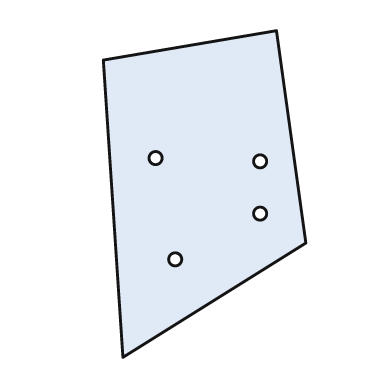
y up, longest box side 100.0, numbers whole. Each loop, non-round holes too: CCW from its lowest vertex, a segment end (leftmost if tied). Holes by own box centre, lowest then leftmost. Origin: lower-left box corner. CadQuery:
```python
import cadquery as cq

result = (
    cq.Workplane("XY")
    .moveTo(6.0, 0.0)
    .lineTo(62.0, 35.0)
    .lineTo(53.0, 100.0)
    .lineTo(0.0, 91.0)
    .close()
    .moveTo(22.0, 30.0)
    .circle(2.0)
    .moveTo(48.0, 44.0)
    .circle(2.0)
    .moveTo(48.0, 60.0)
    .circle(2.0)
    .moveTo(16.0, 61.0)
    .circle(2.0)
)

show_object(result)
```